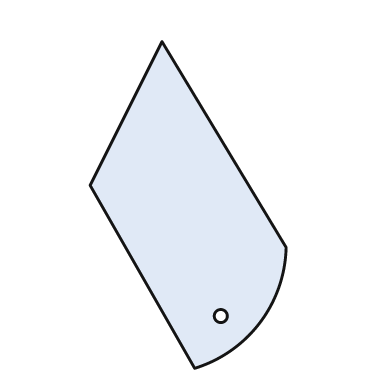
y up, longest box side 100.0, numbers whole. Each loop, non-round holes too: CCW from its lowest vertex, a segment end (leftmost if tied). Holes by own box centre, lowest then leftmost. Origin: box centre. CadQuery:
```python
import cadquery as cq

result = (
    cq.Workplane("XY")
    .moveTo(2.0, -50.0)
    .threePointArc((22.0, -36.0), (30.0, -13.0))
    .lineTo(-8.0, 50.0)
    .lineTo(-30.0, 6.0)
    .close()
    .moveTo(10.0, -34.0)
    .circle(2.0)
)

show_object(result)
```